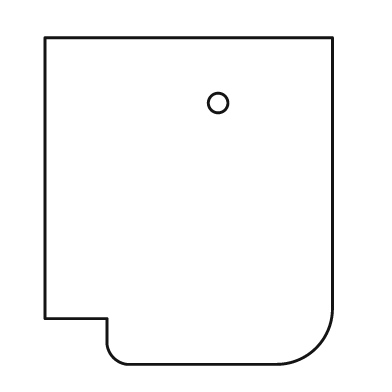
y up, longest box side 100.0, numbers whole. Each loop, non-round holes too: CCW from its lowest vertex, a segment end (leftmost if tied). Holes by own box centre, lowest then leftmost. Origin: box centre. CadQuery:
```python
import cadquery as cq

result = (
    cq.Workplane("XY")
    .moveTo(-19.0, -50.0)
    .lineTo(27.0, -50.0)
    .threePointArc((39.0, -45.0), (44.0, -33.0))
    .lineTo(44.0, 50.0)
    .lineTo(-44.0, 50.0)
    .lineTo(-44.0, -36.0)
    .lineTo(-25.0, -36.0)
    .lineTo(-25.0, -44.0)
    .threePointArc((-23.0, -48.0), (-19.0, -50.0))
    .close()
    .moveTo(9.0, 30.0)
    .circle(3.0)
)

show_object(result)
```